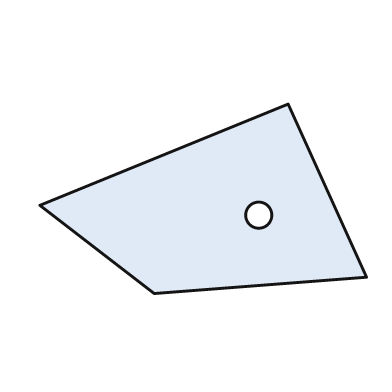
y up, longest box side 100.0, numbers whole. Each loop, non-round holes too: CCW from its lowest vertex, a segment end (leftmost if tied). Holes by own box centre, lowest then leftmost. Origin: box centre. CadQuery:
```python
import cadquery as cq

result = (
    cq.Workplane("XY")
    .moveTo(-15.0, -29.0)
    .lineTo(50.0, -24.0)
    .lineTo(26.0, 29.0)
    .lineTo(-50.0, -2.0)
    .close()
    .moveTo(17.0, -5.0)
    .circle(4.0)
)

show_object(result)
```